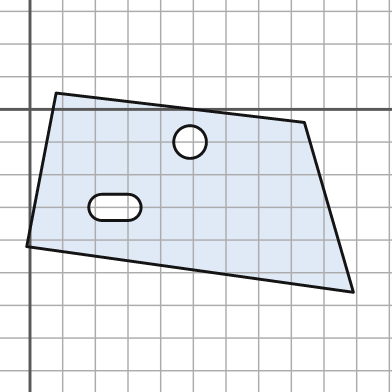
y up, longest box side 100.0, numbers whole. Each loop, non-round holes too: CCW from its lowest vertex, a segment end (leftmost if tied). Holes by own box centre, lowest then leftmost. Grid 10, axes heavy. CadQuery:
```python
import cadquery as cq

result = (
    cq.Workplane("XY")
    .moveTo(99.0, -56.0)
    .lineTo(84.0, -4.0)
    .lineTo(8.0, 5.0)
    .lineTo(-1.0, -42.0)
    .close()
    .moveTo(22.0, -34.0)
    .lineTo(30.0, -34.0)
    .threePointArc((34.0, -30.0), (30.0, -26.0))
    .lineTo(22.0, -26.0)
    .threePointArc((18.0, -30.0), (22.0, -34.0))
    .close()
    .moveTo(49.0, -10.0)
    .circle(5.0)
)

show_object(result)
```